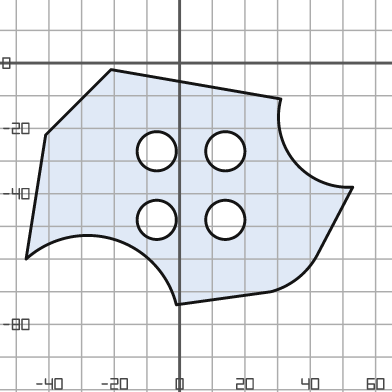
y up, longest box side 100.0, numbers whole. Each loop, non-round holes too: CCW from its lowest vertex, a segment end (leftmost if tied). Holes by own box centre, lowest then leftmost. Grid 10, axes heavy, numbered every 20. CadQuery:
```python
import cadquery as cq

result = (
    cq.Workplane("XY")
    .moveTo(-1.0, -74.0)
    .lineTo(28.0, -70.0)
    .threePointArc((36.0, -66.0), (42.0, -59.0))
    .lineTo(53.0, -38.0)
    .threePointArc((35.0, -30.0), (31.0, -11.0))
    .lineTo(-21.0, -2.0)
    .lineTo(-41.0, -22.0)
    .lineTo(-47.0, -60.0)
    .threePointArc((-20.0, -54.0), (-1.0, -74.0))
    .close()
    .moveTo(-7.0, -48.0)
    .circle(6.0)
    .moveTo(14.0, -48.0)
    .circle(6.0)
    .moveTo(-7.0, -27.0)
    .circle(6.0)
    .moveTo(14.0, -27.0)
    .circle(6.0)
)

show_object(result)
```